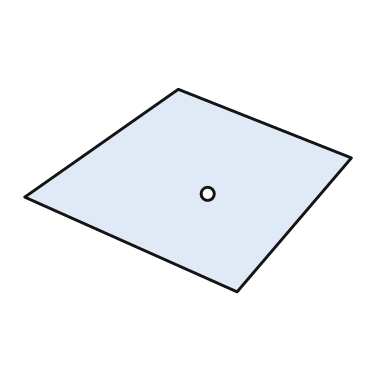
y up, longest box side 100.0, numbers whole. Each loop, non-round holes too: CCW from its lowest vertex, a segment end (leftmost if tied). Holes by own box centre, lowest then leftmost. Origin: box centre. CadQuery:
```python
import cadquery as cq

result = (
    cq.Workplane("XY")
    .moveTo(15.0, -31.0)
    .lineTo(50.0, 10.0)
    .lineTo(-3.0, 31.0)
    .lineTo(-50.0, -2.0)
    .close()
    .moveTo(6.0, -1.0)
    .circle(2.0)
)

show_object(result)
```